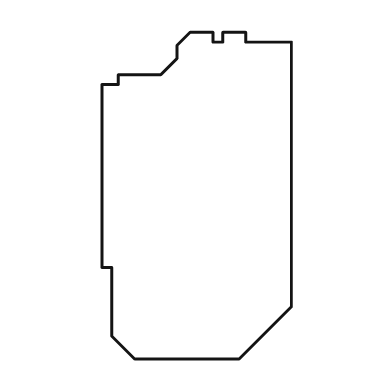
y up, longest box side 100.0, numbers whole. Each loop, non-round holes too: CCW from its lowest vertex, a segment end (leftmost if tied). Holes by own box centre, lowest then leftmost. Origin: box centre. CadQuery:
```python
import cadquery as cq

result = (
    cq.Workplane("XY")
    .moveTo(-19.0, -50.0)
    .lineTo(13.0, -50.0)
    .lineTo(29.0, -34.0)
    .lineTo(29.0, 47.0)
    .lineTo(15.0, 47.0)
    .lineTo(15.0, 50.0)
    .lineTo(8.0, 50.0)
    .lineTo(8.0, 47.0)
    .lineTo(5.0, 47.0)
    .lineTo(5.0, 50.0)
    .lineTo(-2.0, 50.0)
    .lineTo(-6.0, 46.0)
    .lineTo(-6.0, 42.0)
    .lineTo(-11.0, 37.0)
    .lineTo(-24.0, 37.0)
    .lineTo(-24.0, 34.0)
    .lineTo(-29.0, 34.0)
    .lineTo(-29.0, -22.0)
    .lineTo(-26.0, -22.0)
    .lineTo(-26.0, -43.0)
    .close()
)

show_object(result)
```